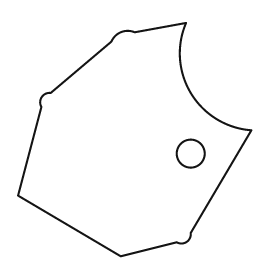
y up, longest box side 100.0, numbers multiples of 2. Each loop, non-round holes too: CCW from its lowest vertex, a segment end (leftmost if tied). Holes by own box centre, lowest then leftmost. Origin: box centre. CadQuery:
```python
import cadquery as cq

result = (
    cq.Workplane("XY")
    .moveTo(-6.0, -50.0)
    .lineTo(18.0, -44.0)
    .threePointArc((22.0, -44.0), (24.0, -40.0))
    .lineTo(50.0, 4.0)
    .threePointArc((24.0, 20.0), (22.0, 50.0))
    .lineTo(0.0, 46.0)
    .threePointArc((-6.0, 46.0), (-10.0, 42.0))
    .lineTo(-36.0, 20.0)
    .threePointArc((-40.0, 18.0), (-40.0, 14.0))
    .lineTo(-50.0, -24.0)
    .close()
    .moveTo(24.0, -6.0)
    .circle(6.0)
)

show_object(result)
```